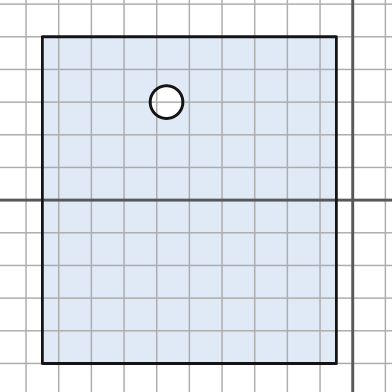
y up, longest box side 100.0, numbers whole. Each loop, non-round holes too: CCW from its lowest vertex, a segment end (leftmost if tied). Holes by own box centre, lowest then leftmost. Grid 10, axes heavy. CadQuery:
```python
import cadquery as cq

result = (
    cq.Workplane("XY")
    .moveTo(-95.0, -50.0)
    .lineTo(-5.0, -50.0)
    .lineTo(-5.0, 50.0)
    .lineTo(-95.0, 50.0)
    .close()
    .moveTo(-57.0, 30.0)
    .circle(5.0)
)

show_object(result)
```